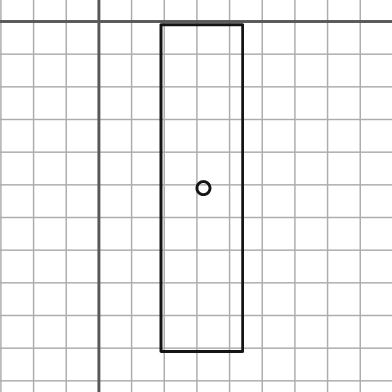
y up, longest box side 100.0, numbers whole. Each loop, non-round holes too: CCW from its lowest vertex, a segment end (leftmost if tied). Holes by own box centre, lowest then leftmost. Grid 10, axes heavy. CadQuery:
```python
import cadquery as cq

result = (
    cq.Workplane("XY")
    .moveTo(19.0, -101.0)
    .lineTo(44.0, -101.0)
    .lineTo(44.0, -1.0)
    .lineTo(19.0, -1.0)
    .close()
    .moveTo(32.0, -51.0)
    .circle(2.0)
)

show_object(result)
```